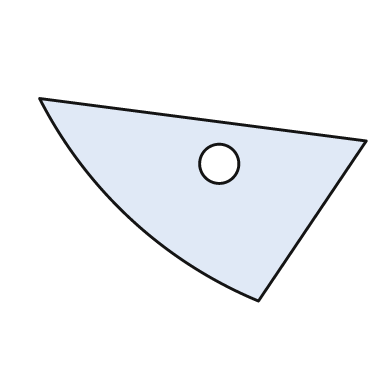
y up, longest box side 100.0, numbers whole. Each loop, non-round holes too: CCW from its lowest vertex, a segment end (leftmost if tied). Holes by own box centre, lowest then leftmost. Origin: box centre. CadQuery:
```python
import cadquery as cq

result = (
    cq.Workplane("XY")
    .moveTo(17.0, -31.0)
    .lineTo(50.0, 18.0)
    .lineTo(-50.0, 31.0)
    .threePointArc((-22.0, -6.0), (17.0, -31.0))
    .close()
    .moveTo(5.0, 11.0)
    .circle(6.0)
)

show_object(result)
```